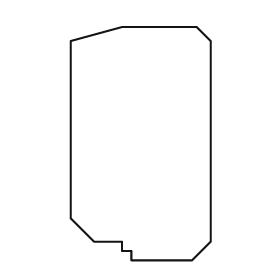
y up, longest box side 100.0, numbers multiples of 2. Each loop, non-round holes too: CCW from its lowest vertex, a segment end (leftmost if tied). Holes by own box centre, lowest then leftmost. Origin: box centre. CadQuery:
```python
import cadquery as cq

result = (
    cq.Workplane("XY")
    .moveTo(-4.0, -50.0)
    .lineTo(22.0, -50.0)
    .lineTo(30.0, -42.0)
    .lineTo(30.0, 44.0)
    .lineTo(24.0, 50.0)
    .lineTo(-8.0, 50.0)
    .lineTo(-30.0, 44.0)
    .lineTo(-30.0, -32.0)
    .lineTo(-20.0, -42.0)
    .lineTo(-8.0, -42.0)
    .lineTo(-8.0, -46.0)
    .lineTo(-4.0, -46.0)
    .close()
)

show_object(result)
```